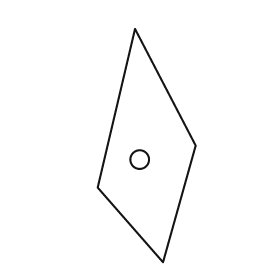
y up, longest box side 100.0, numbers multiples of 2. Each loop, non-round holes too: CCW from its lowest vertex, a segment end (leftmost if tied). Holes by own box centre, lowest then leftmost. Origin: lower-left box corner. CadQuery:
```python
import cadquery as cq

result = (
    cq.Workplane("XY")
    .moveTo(28.0, 0.0)
    .lineTo(42.0, 50.0)
    .lineTo(16.0, 100.0)
    .lineTo(0.0, 32.0)
    .close()
    .moveTo(18.0, 44.0)
    .circle(4.0)
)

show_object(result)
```